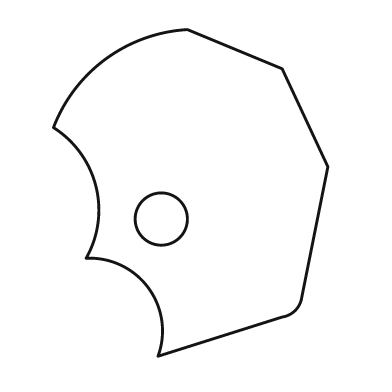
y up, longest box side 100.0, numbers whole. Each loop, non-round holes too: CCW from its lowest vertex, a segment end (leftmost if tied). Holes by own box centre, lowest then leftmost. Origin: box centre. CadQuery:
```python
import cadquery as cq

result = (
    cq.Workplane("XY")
    .moveTo(-10.0, -50.0)
    .lineTo(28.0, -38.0)
    .threePointArc((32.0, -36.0), (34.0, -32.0))
    .lineTo(42.0, 8.0)
    .lineTo(28.0, 38.0)
    .lineTo(-1.0, 50.0)
    .threePointArc((-26.0, 41.0), (-42.0, 20.0))
    .threePointArc((-29.0, 2.0), (-32.0, -20.0))
    .threePointArc((-13.0, -29.0), (-10.0, -50.0))
    .close()
    .moveTo(-9.0, -8.0)
    .circle(8.0)
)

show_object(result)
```